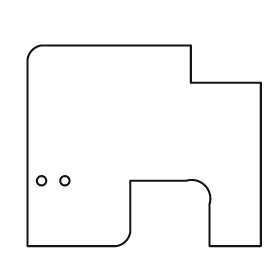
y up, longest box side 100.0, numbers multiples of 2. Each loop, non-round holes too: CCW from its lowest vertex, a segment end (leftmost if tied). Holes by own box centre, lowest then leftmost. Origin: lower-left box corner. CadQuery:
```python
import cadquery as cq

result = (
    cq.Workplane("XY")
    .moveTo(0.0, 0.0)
    .lineTo(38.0, 0.0)
    .threePointArc((42.0, 2.0), (44.0, 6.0))
    .lineTo(44.0, 28.0)
    .lineTo(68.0, 28.0)
    .threePointArc((76.0, 26.0), (78.0, 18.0))
    .lineTo(78.0, 0.0)
    .lineTo(100.0, 0.0)
    .lineTo(100.0, 70.0)
    .lineTo(70.0, 70.0)
    .lineTo(70.0, 86.0)
    .lineTo(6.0, 86.0)
    .threePointArc((2.0, 84.0), (0.0, 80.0))
    .close()
    .moveTo(6.0, 28.0)
    .circle(2.0)
    .moveTo(16.0, 28.0)
    .circle(2.0)
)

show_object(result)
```